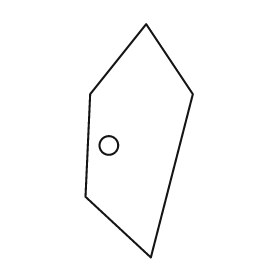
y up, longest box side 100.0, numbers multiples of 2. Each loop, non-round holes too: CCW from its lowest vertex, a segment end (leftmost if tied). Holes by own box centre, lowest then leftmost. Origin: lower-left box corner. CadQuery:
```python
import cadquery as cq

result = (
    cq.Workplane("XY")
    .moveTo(28.0, 0.0)
    .lineTo(46.0, 70.0)
    .lineTo(26.0, 100.0)
    .lineTo(2.0, 70.0)
    .lineTo(0.0, 26.0)
    .close()
    .moveTo(10.0, 48.0)
    .circle(4.0)
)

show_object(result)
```